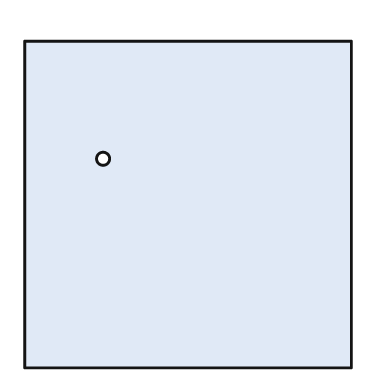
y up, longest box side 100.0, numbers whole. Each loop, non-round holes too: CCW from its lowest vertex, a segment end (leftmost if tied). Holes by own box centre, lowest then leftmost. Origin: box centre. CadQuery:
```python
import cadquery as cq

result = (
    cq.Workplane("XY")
    .moveTo(-50.0, -50.0)
    .lineTo(50.0, -50.0)
    .lineTo(50.0, 50.0)
    .lineTo(-50.0, 50.0)
    .close()
    .moveTo(-26.0, 14.0)
    .circle(2.0)
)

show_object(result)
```